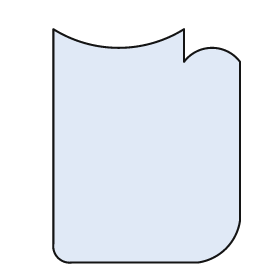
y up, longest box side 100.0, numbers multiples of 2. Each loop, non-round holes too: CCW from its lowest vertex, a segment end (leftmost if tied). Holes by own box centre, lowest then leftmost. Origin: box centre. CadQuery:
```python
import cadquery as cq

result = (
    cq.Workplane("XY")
    .moveTo(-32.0, -50.0)
    .lineTo(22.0, -50.0)
    .threePointArc((34.0, -44.0), (40.0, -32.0))
    .lineTo(40.0, 36.0)
    .threePointArc((28.0, 42.0), (16.0, 36.0))
    .lineTo(16.0, 50.0)
    .threePointArc((-12.0, 42.0), (-40.0, 50.0))
    .lineTo(-40.0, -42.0)
    .threePointArc((-38.0, -48.0), (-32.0, -50.0))
    .close()
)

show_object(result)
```